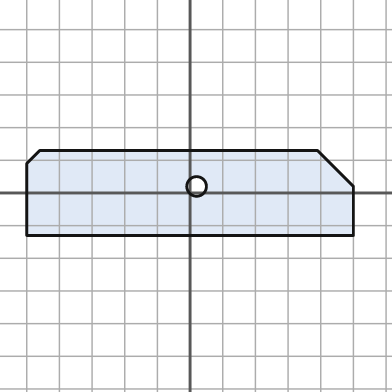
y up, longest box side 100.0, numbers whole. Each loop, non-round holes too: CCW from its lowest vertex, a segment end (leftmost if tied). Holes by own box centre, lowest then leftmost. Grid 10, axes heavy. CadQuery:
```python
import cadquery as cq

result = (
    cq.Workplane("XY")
    .moveTo(-50.0, -13.0)
    .lineTo(50.0, -13.0)
    .lineTo(50.0, 2.0)
    .lineTo(39.0, 13.0)
    .lineTo(-46.0, 13.0)
    .lineTo(-50.0, 9.0)
    .close()
    .moveTo(2.0, 2.0)
    .circle(3.0)
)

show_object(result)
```